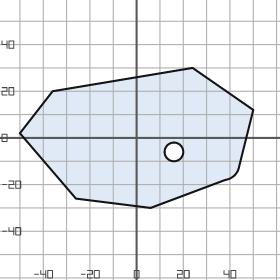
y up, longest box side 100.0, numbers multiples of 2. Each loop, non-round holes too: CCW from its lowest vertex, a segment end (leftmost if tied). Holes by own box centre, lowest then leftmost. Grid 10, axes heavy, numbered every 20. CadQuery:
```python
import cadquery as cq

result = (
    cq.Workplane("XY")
    .moveTo(6.0, -30.0)
    .lineTo(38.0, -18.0)
    .threePointArc((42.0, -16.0), (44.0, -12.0))
    .lineTo(50.0, 12.0)
    .lineTo(24.0, 30.0)
    .lineTo(-36.0, 20.0)
    .lineTo(-50.0, 2.0)
    .lineTo(-26.0, -26.0)
    .close()
    .moveTo(16.0, -6.0)
    .circle(4.0)
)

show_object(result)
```